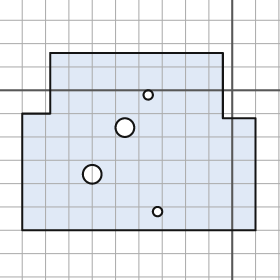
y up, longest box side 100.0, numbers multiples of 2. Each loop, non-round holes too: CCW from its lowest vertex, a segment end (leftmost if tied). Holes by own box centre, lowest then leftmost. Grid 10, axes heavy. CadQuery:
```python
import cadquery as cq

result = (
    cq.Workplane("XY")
    .moveTo(-90.0, -60.0)
    .lineTo(10.0, -60.0)
    .lineTo(10.0, -12.0)
    .lineTo(-4.0, -12.0)
    .lineTo(-4.0, 16.0)
    .lineTo(-78.0, 16.0)
    .lineTo(-78.0, -10.0)
    .lineTo(-90.0, -10.0)
    .close()
    .moveTo(-32.0, -52.0)
    .circle(2.0)
    .moveTo(-60.0, -36.0)
    .circle(4.0)
    .moveTo(-46.0, -16.0)
    .circle(4.0)
    .moveTo(-36.0, -2.0)
    .circle(2.0)
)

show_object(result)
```